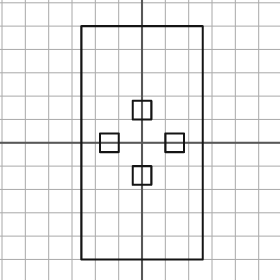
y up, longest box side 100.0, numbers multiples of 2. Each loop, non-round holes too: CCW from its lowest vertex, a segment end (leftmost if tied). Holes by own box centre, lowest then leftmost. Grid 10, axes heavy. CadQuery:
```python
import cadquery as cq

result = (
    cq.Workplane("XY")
    .moveTo(-26.0, -50.0)
    .lineTo(26.0, -50.0)
    .lineTo(26.0, 50.0)
    .lineTo(-26.0, 50.0)
    .close()
    .moveTo(-4.0, -18.0)
    .lineTo(4.0, -18.0)
    .lineTo(4.0, -10.0)
    .lineTo(-4.0, -10.0)
    .close()
    .moveTo(-18.0, -4.0)
    .lineTo(-10.0, -4.0)
    .lineTo(-10.0, 4.0)
    .lineTo(-18.0, 4.0)
    .close()
    .moveTo(10.0, -4.0)
    .lineTo(18.0, -4.0)
    .lineTo(18.0, 4.0)
    .lineTo(10.0, 4.0)
    .close()
    .moveTo(-4.0, 10.0)
    .lineTo(4.0, 10.0)
    .lineTo(4.0, 18.0)
    .lineTo(-4.0, 18.0)
    .close()
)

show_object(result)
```